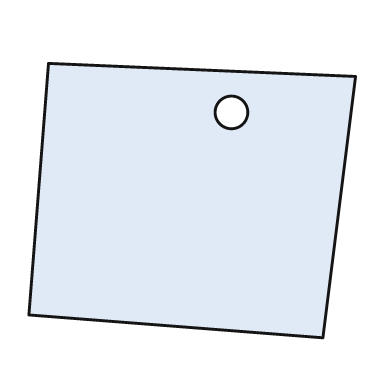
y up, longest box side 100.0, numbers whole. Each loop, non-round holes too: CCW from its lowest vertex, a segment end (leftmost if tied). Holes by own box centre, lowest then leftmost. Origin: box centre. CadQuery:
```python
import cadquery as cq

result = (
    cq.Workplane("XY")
    .moveTo(40.0, -42.0)
    .lineTo(50.0, 38.0)
    .lineTo(-44.0, 42.0)
    .lineTo(-50.0, -35.0)
    .close()
    .moveTo(12.0, 27.0)
    .circle(5.0)
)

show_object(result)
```